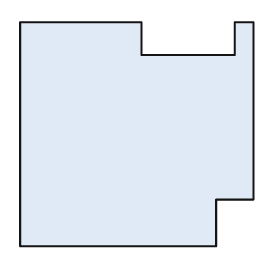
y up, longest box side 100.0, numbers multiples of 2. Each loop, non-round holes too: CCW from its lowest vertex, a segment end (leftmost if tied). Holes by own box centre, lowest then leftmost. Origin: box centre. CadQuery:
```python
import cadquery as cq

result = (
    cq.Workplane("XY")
    .moveTo(-50.0, -48.0)
    .lineTo(34.0, -48.0)
    .lineTo(34.0, -28.0)
    .lineTo(50.0, -28.0)
    .lineTo(50.0, 48.0)
    .lineTo(42.0, 48.0)
    .lineTo(42.0, 34.0)
    .lineTo(2.0, 34.0)
    .lineTo(2.0, 48.0)
    .lineTo(-50.0, 48.0)
    .close()
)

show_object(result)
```